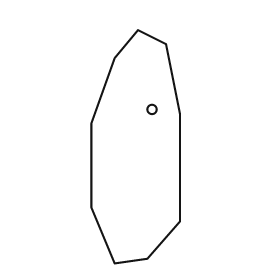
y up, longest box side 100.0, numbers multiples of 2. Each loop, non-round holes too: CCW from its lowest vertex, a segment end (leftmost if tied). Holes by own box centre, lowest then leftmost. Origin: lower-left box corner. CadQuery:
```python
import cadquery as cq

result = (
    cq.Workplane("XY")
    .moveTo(10.0, 0.0)
    .lineTo(24.0, 2.0)
    .lineTo(38.0, 18.0)
    .lineTo(38.0, 64.0)
    .lineTo(32.0, 94.0)
    .lineTo(20.0, 100.0)
    .lineTo(10.0, 88.0)
    .lineTo(0.0, 60.0)
    .lineTo(0.0, 24.0)
    .close()
    .moveTo(26.0, 66.0)
    .circle(2.0)
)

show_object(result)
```